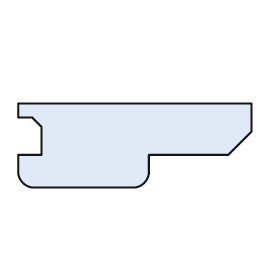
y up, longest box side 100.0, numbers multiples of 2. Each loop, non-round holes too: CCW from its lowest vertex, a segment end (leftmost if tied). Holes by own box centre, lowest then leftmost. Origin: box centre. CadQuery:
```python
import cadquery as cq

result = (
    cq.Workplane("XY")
    .moveTo(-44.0, -18.0)
    .lineTo(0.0, -18.0)
    .threePointArc((4.0, -16.0), (6.0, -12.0))
    .lineTo(6.0, -4.0)
    .lineTo(40.0, -4.0)
    .lineTo(50.0, 6.0)
    .lineTo(50.0, 18.0)
    .lineTo(-50.0, 18.0)
    .lineTo(-50.0, 12.0)
    .lineTo(-44.0, 12.0)
    .lineTo(-40.0, 8.0)
    .lineTo(-40.0, -4.0)
    .lineTo(-50.0, -4.0)
    .lineTo(-50.0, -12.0)
    .threePointArc((-48.0, -16.0), (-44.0, -18.0))
    .close()
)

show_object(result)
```